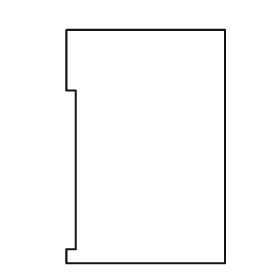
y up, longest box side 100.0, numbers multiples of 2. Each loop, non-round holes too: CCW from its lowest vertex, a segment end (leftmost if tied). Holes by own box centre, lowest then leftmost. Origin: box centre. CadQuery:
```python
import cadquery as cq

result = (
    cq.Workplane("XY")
    .moveTo(-34.0, -50.0)
    .lineTo(34.0, -50.0)
    .lineTo(34.0, 50.0)
    .lineTo(-34.0, 50.0)
    .lineTo(-34.0, 24.0)
    .lineTo(-30.0, 24.0)
    .lineTo(-30.0, -44.0)
    .lineTo(-34.0, -44.0)
    .close()
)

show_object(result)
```